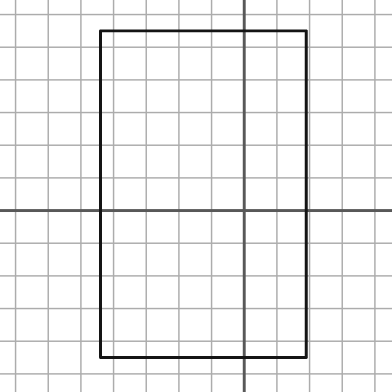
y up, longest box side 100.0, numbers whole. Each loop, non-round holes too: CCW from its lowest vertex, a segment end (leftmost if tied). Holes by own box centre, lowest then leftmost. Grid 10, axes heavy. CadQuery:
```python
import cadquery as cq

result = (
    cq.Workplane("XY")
    .moveTo(-44.0, -45.0)
    .lineTo(19.0, -45.0)
    .lineTo(19.0, 55.0)
    .lineTo(-44.0, 55.0)
    .close()
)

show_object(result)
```